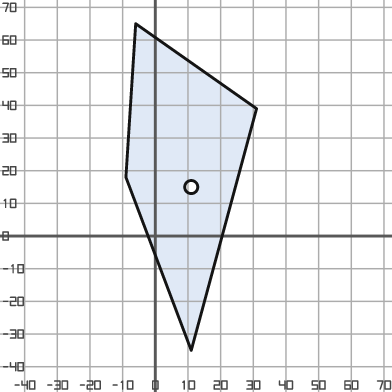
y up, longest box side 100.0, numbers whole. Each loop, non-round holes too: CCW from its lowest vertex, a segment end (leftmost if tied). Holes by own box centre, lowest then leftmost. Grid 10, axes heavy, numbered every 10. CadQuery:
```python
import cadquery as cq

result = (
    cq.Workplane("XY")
    .moveTo(11.0, -35.0)
    .lineTo(31.0, 39.0)
    .lineTo(-6.0, 65.0)
    .lineTo(-9.0, 18.0)
    .close()
    .moveTo(11.0, 15.0)
    .circle(2.0)
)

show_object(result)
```